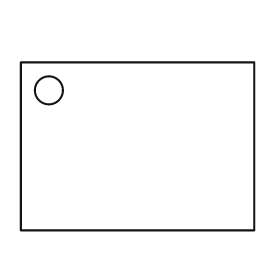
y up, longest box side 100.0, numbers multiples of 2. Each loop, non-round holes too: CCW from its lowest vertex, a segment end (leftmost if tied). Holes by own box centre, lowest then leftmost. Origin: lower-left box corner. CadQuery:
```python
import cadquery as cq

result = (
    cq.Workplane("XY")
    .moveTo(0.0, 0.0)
    .lineTo(100.0, 0.0)
    .lineTo(100.0, 72.0)
    .lineTo(0.0, 72.0)
    .close()
    .moveTo(12.0, 60.0)
    .circle(6.0)
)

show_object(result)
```